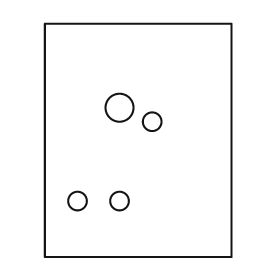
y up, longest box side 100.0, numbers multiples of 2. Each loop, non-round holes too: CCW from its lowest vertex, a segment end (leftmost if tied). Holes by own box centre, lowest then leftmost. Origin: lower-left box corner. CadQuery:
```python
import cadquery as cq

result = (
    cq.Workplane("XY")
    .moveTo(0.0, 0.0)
    .lineTo(80.0, 0.0)
    .lineTo(80.0, 100.0)
    .lineTo(0.0, 100.0)
    .close()
    .moveTo(14.0, 24.0)
    .circle(4.0)
    .moveTo(32.0, 24.0)
    .circle(4.0)
    .moveTo(46.0, 58.0)
    .circle(4.0)
    .moveTo(32.0, 64.0)
    .circle(6.0)
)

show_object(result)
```